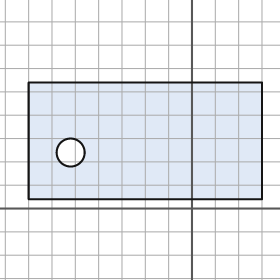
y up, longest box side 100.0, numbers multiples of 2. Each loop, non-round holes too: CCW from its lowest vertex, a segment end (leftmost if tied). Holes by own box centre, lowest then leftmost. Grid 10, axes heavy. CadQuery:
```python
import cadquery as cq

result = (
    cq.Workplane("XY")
    .moveTo(-70.0, 4.0)
    .lineTo(30.0, 4.0)
    .lineTo(30.0, 54.0)
    .lineTo(-70.0, 54.0)
    .close()
    .moveTo(-52.0, 24.0)
    .circle(6.0)
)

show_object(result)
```